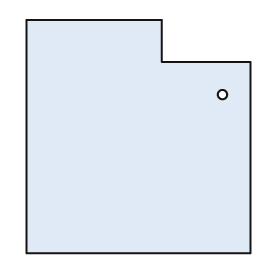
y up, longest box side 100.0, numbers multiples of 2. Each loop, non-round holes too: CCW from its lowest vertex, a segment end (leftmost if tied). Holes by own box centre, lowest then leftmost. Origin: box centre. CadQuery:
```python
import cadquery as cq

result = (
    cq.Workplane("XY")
    .moveTo(-48.0, -50.0)
    .lineTo(48.0, -50.0)
    .lineTo(48.0, 32.0)
    .lineTo(10.0, 32.0)
    .lineTo(10.0, 50.0)
    .lineTo(-48.0, 50.0)
    .close()
    .moveTo(36.0, 18.0)
    .circle(2.0)
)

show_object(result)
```